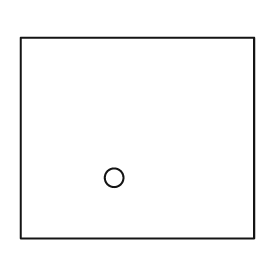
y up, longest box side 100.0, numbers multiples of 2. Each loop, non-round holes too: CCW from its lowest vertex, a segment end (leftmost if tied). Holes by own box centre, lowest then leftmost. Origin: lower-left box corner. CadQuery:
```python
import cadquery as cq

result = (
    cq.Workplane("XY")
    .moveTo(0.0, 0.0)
    .lineTo(100.0, 0.0)
    .lineTo(100.0, 86.0)
    .lineTo(0.0, 86.0)
    .close()
    .moveTo(40.0, 26.0)
    .circle(4.0)
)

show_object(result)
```